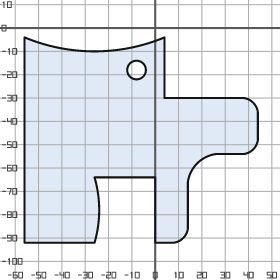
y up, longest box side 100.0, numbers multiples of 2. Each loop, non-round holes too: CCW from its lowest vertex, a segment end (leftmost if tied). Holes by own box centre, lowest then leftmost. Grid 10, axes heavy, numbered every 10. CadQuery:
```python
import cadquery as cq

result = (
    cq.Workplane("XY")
    .moveTo(-56.0, -92.0)
    .lineTo(-26.0, -92.0)
    .threePointArc((-24.0, -78.0), (-26.0, -64.0))
    .lineTo(0.0, -64.0)
    .lineTo(0.0, -92.0)
    .lineTo(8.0, -92.0)
    .threePointArc((12.0, -90.0), (14.0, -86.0))
    .lineTo(14.0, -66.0)
    .threePointArc((18.0, -58.0), (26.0, -54.0))
    .lineTo(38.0, -54.0)
    .threePointArc((42.0, -52.0), (44.0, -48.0))
    .lineTo(44.0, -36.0)
    .threePointArc((42.0, -32.0), (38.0, -30.0))
    .lineTo(4.0, -30.0)
    .lineTo(4.0, -4.0)
    .threePointArc((-26.0, -10.0), (-56.0, -4.0))
    .close()
    .moveTo(-8.0, -18.0)
    .circle(4.0)
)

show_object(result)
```